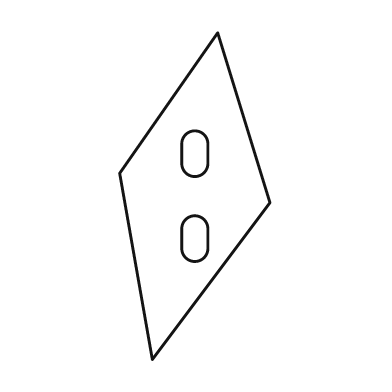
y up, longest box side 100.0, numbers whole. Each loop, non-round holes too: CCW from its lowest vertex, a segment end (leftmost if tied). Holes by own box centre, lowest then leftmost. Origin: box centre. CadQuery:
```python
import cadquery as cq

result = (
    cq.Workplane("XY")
    .moveTo(-13.0, -50.0)
    .lineTo(23.0, -2.0)
    .lineTo(7.0, 50.0)
    .lineTo(-23.0, 7.0)
    .close()
    .moveTo(-4.0, -16.0)
    .threePointArc((0.0, -20.0), (4.0, -16.0))
    .lineTo(4.0, -10.0)
    .threePointArc((0.0, -6.0), (-4.0, -10.0))
    .close()
    .moveTo(-4.0, 10.0)
    .threePointArc((0.0, 6.0), (4.0, 10.0))
    .lineTo(4.0, 16.0)
    .threePointArc((0.0, 20.0), (-4.0, 16.0))
    .close()
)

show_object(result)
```